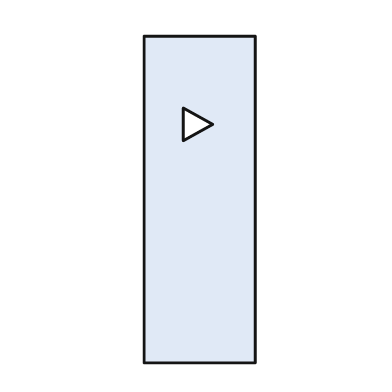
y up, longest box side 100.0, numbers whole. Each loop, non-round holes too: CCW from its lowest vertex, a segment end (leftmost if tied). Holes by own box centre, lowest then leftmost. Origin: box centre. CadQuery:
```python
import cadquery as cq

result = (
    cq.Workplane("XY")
    .moveTo(-17.0, -50.0)
    .lineTo(17.0, -50.0)
    .lineTo(17.0, 50.0)
    .lineTo(-17.0, 50.0)
    .close()
    .moveTo(-5.0, 18.0)
    .lineTo(4.0, 23.0)
    .lineTo(-5.0, 28.0)
    .close()
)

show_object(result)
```